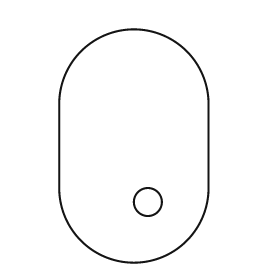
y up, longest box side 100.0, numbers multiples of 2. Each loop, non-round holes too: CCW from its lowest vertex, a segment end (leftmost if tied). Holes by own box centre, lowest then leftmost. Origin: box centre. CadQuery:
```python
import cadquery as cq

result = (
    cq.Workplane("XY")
    .moveTo(-32.0, -18.0)
    .threePointArc((0.0, -50.0), (32.0, -18.0))
    .lineTo(32.0, 18.0)
    .threePointArc((0.0, 50.0), (-32.0, 18.0))
    .close()
    .moveTo(6.0, -24.0)
    .circle(6.0)
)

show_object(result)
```